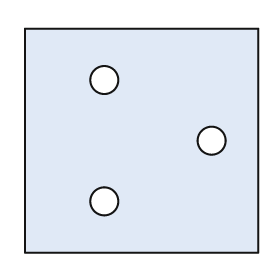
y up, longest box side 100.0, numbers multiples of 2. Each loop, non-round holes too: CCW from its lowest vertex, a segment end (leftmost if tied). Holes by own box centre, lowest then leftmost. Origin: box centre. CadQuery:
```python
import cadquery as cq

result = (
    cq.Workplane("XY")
    .moveTo(-50.0, -48.0)
    .lineTo(50.0, -48.0)
    .lineTo(50.0, 48.0)
    .lineTo(-50.0, 48.0)
    .close()
    .moveTo(-16.0, -26.0)
    .circle(6.0)
    .moveTo(30.0, 0.0)
    .circle(6.0)
    .moveTo(-16.0, 26.0)
    .circle(6.0)
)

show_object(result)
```